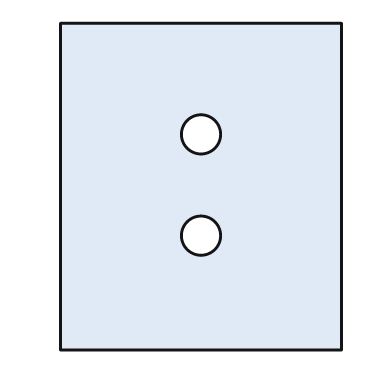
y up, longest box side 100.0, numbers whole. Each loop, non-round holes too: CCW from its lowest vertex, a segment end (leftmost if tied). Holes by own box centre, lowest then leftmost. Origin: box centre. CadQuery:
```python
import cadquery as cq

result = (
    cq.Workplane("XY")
    .moveTo(-43.0, -50.0)
    .lineTo(43.0, -50.0)
    .lineTo(43.0, 50.0)
    .lineTo(-43.0, 50.0)
    .close()
    .moveTo(0.0, -15.0)
    .circle(6.0)
    .moveTo(0.0, 16.0)
    .circle(6.0)
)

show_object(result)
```